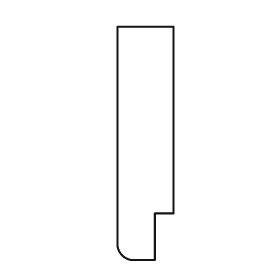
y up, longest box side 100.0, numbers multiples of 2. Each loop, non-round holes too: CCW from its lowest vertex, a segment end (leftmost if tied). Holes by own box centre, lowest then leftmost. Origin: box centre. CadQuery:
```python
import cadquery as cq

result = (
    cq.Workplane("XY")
    .moveTo(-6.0, -50.0)
    .lineTo(4.0, -50.0)
    .lineTo(4.0, -30.0)
    .lineTo(12.0, -30.0)
    .lineTo(12.0, 50.0)
    .lineTo(-12.0, 50.0)
    .lineTo(-12.0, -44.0)
    .threePointArc((-10.0, -48.0), (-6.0, -50.0))
    .close()
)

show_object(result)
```